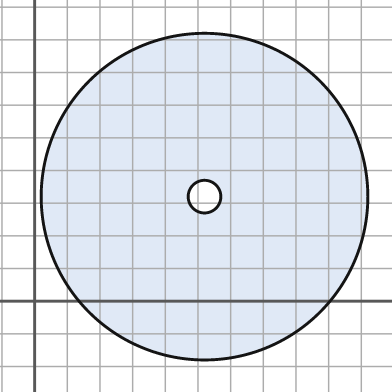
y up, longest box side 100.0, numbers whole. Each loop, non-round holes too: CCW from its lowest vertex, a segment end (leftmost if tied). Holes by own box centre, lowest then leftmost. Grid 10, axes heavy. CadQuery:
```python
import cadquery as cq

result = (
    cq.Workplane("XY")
    .moveTo(52.0, 32.0)
    .circle(50.0)
    .moveTo(52.0, 32.0)
    .circle(5.0)
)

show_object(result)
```